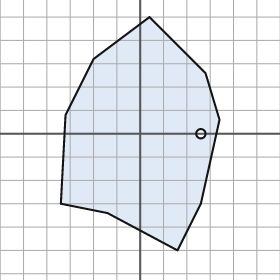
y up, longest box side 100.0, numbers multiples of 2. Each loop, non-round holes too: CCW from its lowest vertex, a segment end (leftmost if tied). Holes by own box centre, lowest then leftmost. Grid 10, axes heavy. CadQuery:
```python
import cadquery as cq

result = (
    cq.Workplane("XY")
    .moveTo(16.0, -50.0)
    .lineTo(26.0, -30.0)
    .lineTo(34.0, 6.0)
    .lineTo(28.0, 26.0)
    .lineTo(4.0, 50.0)
    .lineTo(-20.0, 32.0)
    .lineTo(-32.0, 8.0)
    .lineTo(-34.0, -30.0)
    .lineTo(-14.0, -34.0)
    .close()
    .moveTo(26.0, 0.0)
    .circle(2.0)
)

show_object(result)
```